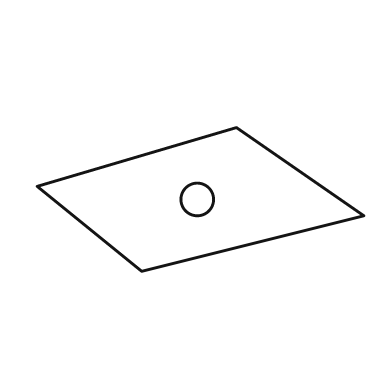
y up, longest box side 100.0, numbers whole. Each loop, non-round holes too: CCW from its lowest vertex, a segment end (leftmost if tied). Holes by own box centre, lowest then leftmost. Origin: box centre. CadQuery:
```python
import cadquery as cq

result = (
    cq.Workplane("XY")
    .moveTo(-18.0, -22.0)
    .lineTo(50.0, -5.0)
    .lineTo(11.0, 22.0)
    .lineTo(-50.0, 4.0)
    .close()
    .moveTo(-1.0, 0.0)
    .circle(5.0)
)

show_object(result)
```